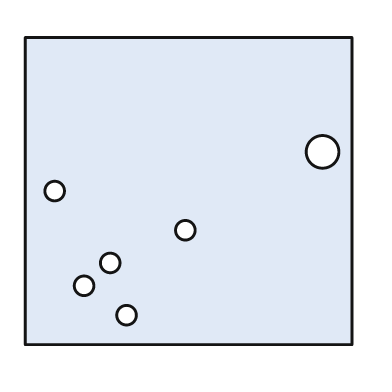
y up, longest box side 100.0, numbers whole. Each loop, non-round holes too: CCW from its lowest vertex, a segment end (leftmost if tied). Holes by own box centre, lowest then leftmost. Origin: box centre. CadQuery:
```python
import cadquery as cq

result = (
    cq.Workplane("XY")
    .moveTo(-50.0, -47.0)
    .lineTo(50.0, -47.0)
    .lineTo(50.0, 47.0)
    .lineTo(-50.0, 47.0)
    .close()
    .moveTo(-19.0, -38.0)
    .circle(3.0)
    .moveTo(-32.0, -29.0)
    .circle(3.0)
    .moveTo(-24.0, -22.0)
    .circle(3.0)
    .moveTo(-1.0, -12.0)
    .circle(3.0)
    .moveTo(-41.0, 0.0)
    .circle(3.0)
    .moveTo(41.0, 12.0)
    .circle(5.0)
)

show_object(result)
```